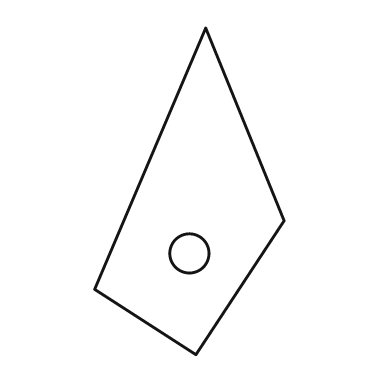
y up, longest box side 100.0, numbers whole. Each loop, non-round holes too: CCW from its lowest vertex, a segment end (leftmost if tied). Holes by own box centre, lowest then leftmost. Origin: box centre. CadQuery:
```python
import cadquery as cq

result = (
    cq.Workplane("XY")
    .moveTo(2.0, -50.0)
    .lineTo(29.0, -9.0)
    .lineTo(5.0, 50.0)
    .lineTo(-29.0, -30.0)
    .close()
    .moveTo(0.0, -19.0)
    .circle(6.0)
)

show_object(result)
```